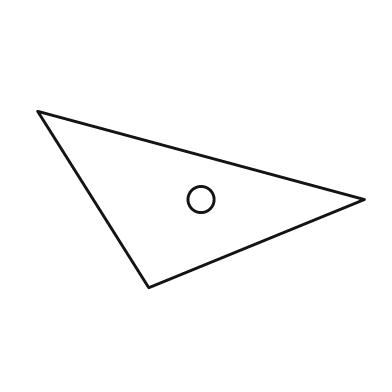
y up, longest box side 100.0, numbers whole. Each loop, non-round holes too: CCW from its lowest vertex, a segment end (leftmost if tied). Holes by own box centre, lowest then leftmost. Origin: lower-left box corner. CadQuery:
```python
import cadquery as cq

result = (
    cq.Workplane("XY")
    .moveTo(34.0, 0.0)
    .lineTo(100.0, 27.0)
    .lineTo(0.0, 54.0)
    .close()
    .moveTo(50.0, 27.0)
    .circle(4.0)
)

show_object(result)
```